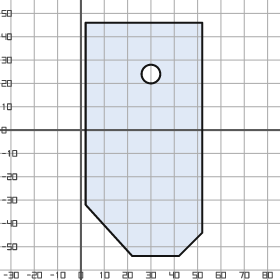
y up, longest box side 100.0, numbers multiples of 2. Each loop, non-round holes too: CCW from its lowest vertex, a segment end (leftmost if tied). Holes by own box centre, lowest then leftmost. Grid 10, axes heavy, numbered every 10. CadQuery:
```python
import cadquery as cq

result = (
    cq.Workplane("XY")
    .moveTo(22.0, -54.0)
    .lineTo(42.0, -54.0)
    .lineTo(52.0, -44.0)
    .lineTo(52.0, 46.0)
    .lineTo(2.0, 46.0)
    .lineTo(2.0, -32.0)
    .close()
    .moveTo(30.0, 24.0)
    .circle(4.0)
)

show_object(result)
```